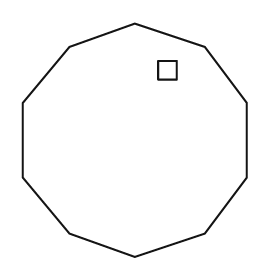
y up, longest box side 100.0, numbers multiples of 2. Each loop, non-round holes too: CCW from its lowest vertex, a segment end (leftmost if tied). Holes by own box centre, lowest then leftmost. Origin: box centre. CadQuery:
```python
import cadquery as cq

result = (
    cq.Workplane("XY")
    .moveTo(0.0, -50.0)
    .lineTo(30.0, -40.0)
    .lineTo(48.0, -16.0)
    .lineTo(48.0, 16.0)
    .lineTo(30.0, 40.0)
    .lineTo(0.0, 50.0)
    .lineTo(-28.0, 40.0)
    .lineTo(-48.0, 16.0)
    .lineTo(-48.0, -16.0)
    .lineTo(-28.0, -40.0)
    .close()
    .moveTo(10.0, 26.0)
    .lineTo(18.0, 26.0)
    .lineTo(18.0, 34.0)
    .lineTo(10.0, 34.0)
    .close()
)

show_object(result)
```